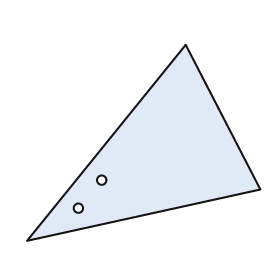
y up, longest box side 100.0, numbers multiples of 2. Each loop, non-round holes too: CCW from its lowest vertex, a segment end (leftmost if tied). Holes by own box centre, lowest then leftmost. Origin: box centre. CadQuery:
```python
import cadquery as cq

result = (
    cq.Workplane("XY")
    .moveTo(-50.0, -42.0)
    .lineTo(50.0, -20.0)
    .lineTo(18.0, 42.0)
    .close()
    .moveTo(-28.0, -28.0)
    .circle(2.0)
    .moveTo(-18.0, -16.0)
    .circle(2.0)
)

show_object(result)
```